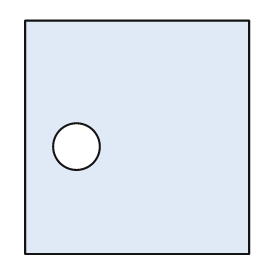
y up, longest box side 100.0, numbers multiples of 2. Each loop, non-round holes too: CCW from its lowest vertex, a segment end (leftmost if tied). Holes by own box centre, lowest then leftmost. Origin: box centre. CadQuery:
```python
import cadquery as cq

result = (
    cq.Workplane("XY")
    .moveTo(-48.0, -50.0)
    .lineTo(48.0, -50.0)
    .lineTo(48.0, 50.0)
    .lineTo(-48.0, 50.0)
    .close()
    .moveTo(-26.0, -4.0)
    .circle(10.0)
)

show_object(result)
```